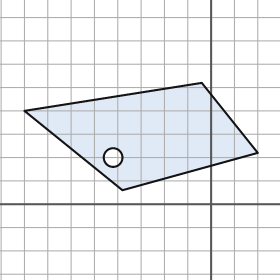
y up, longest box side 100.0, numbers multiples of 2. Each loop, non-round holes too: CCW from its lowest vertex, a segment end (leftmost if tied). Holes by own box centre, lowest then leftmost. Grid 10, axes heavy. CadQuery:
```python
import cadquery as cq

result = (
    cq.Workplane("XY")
    .moveTo(-38.0, 6.0)
    .lineTo(20.0, 22.0)
    .lineTo(-4.0, 52.0)
    .lineTo(-80.0, 40.0)
    .close()
    .moveTo(-42.0, 20.0)
    .circle(4.0)
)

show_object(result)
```